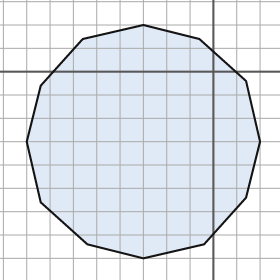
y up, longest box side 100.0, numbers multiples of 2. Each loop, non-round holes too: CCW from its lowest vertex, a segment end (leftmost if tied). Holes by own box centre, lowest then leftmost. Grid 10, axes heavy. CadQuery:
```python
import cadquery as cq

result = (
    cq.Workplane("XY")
    .moveTo(-30.0, -80.0)
    .lineTo(-4.0, -74.0)
    .lineTo(14.0, -54.0)
    .lineTo(20.0, -30.0)
    .lineTo(14.0, -4.0)
    .lineTo(-6.0, 14.0)
    .lineTo(-30.0, 20.0)
    .lineTo(-56.0, 14.0)
    .lineTo(-74.0, -6.0)
    .lineTo(-80.0, -30.0)
    .lineTo(-74.0, -56.0)
    .lineTo(-54.0, -74.0)
    .close()
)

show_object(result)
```